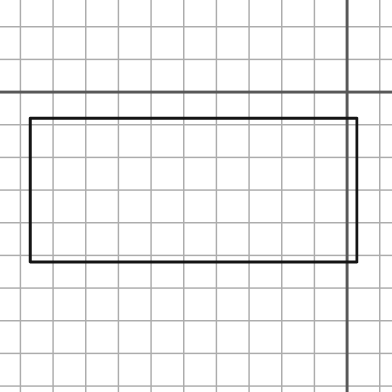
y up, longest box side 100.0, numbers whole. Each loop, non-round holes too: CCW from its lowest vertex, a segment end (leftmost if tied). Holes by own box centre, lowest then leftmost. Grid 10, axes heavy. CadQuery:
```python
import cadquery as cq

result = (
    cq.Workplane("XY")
    .moveTo(-97.0, -52.0)
    .lineTo(3.0, -52.0)
    .lineTo(3.0, -8.0)
    .lineTo(-97.0, -8.0)
    .close()
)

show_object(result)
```